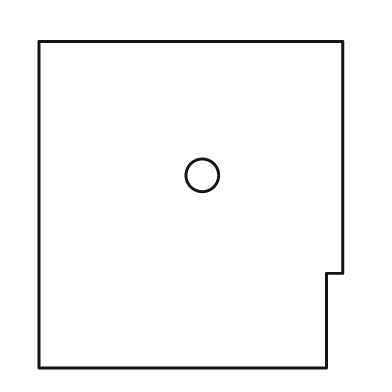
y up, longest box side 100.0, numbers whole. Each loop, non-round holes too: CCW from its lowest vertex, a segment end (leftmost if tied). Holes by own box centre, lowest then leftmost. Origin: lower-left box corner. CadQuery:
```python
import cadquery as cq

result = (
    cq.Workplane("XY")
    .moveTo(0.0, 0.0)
    .lineTo(88.0, 0.0)
    .lineTo(88.0, 29.0)
    .lineTo(93.0, 29.0)
    .lineTo(93.0, 100.0)
    .lineTo(0.0, 100.0)
    .close()
    .moveTo(50.0, 59.0)
    .circle(5.0)
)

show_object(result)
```